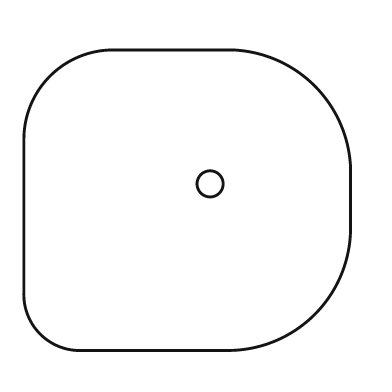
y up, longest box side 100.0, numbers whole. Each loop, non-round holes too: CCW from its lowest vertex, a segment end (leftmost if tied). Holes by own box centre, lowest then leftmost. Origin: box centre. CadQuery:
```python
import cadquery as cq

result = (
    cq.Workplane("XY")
    .moveTo(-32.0, -46.0)
    .lineTo(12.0, -46.0)
    .threePointArc((39.0, -35.0), (50.0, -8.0))
    .lineTo(50.0, 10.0)
    .threePointArc((39.0, 35.0), (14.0, 46.0))
    .lineTo(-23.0, 46.0)
    .threePointArc((-42.0, 38.0), (-50.0, 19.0))
    .lineTo(-50.0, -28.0)
    .threePointArc((-45.0, -41.0), (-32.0, -46.0))
    .close()
    .moveTo(7.0, 5.0)
    .circle(4.0)
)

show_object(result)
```